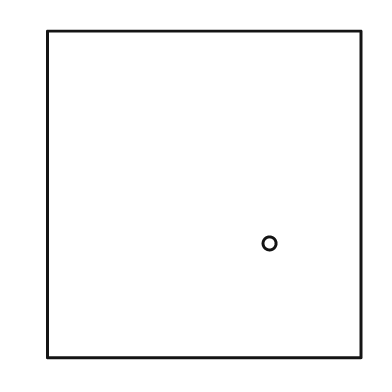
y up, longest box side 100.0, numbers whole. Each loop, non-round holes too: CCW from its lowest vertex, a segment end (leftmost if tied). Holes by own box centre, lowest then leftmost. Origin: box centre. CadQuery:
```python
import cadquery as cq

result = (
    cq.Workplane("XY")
    .moveTo(-48.0, -50.0)
    .lineTo(48.0, -50.0)
    .lineTo(48.0, 50.0)
    .lineTo(-48.0, 50.0)
    .close()
    .moveTo(20.0, -15.0)
    .circle(2.0)
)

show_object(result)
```